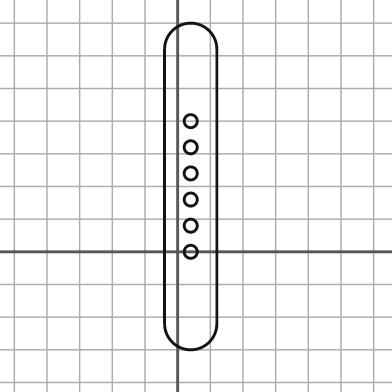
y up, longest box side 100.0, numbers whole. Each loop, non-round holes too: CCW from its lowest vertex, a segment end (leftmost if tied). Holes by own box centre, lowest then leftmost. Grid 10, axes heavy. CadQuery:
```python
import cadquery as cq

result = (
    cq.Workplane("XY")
    .moveTo(-4.0, -22.0)
    .threePointArc((4.0, -30.0), (12.0, -22.0))
    .lineTo(12.0, 62.0)
    .threePointArc((4.0, 70.0), (-4.0, 62.0))
    .close()
    .moveTo(4.0, 0.0)
    .circle(2.0)
    .moveTo(4.0, 8.0)
    .circle(2.0)
    .moveTo(4.0, 16.0)
    .circle(2.0)
    .moveTo(4.0, 24.0)
    .circle(2.0)
    .moveTo(4.0, 32.0)
    .circle(2.0)
    .moveTo(4.0, 40.0)
    .circle(2.0)
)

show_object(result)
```